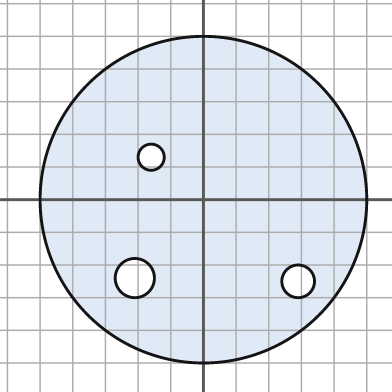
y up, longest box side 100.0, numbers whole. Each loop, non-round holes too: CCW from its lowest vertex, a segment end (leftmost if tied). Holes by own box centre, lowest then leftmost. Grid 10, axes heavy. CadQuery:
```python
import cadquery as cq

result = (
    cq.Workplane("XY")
    .moveTo(0.0, 0.0)
    .circle(50.0)
    .moveTo(29.0, -25.0)
    .circle(5.0)
    .moveTo(-21.0, -24.0)
    .circle(6.0)
    .moveTo(-16.0, 13.0)
    .circle(4.0)
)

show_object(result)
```